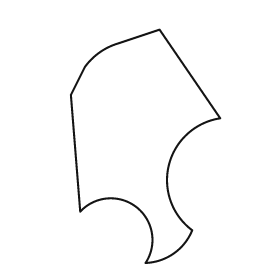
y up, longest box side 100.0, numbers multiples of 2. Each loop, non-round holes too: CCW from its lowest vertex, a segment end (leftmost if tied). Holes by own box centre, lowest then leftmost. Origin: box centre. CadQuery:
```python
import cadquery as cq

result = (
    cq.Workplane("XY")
    .moveTo(0.0, -50.0)
    .threePointArc((12.0, -46.0), (20.0, -36.0))
    .threePointArc((10.0, -8.0), (32.0, 12.0))
    .lineTo(6.0, 50.0)
    .lineTo(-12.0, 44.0)
    .threePointArc((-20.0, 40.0), (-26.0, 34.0))
    .lineTo(-32.0, 22.0)
    .lineTo(-28.0, -28.0)
    .threePointArc((-4.0, -26.0), (0.0, -50.0))
    .close()
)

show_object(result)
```